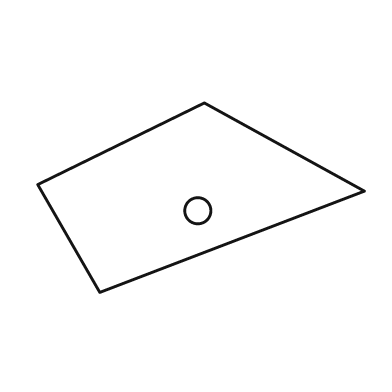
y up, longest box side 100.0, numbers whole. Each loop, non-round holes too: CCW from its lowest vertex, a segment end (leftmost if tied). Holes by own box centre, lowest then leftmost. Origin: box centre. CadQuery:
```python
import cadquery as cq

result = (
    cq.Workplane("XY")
    .moveTo(-31.0, -29.0)
    .lineTo(50.0, 2.0)
    .lineTo(1.0, 29.0)
    .lineTo(-50.0, 4.0)
    .close()
    .moveTo(-1.0, -4.0)
    .circle(4.0)
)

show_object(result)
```